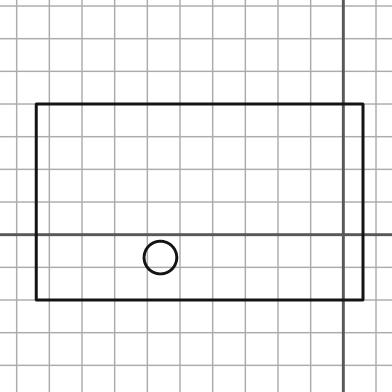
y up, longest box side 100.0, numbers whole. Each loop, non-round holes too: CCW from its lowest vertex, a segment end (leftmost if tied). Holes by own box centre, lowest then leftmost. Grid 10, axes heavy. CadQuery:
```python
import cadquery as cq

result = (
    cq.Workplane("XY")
    .moveTo(-94.0, -20.0)
    .lineTo(6.0, -20.0)
    .lineTo(6.0, 40.0)
    .lineTo(-94.0, 40.0)
    .close()
    .moveTo(-56.0, -7.0)
    .circle(5.0)
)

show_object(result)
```